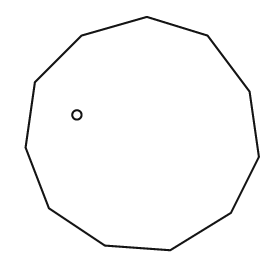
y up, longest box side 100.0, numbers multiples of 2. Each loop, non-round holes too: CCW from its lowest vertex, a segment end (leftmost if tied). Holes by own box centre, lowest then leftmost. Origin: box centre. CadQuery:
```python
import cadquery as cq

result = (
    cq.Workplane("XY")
    .moveTo(12.0, -50.0)
    .lineTo(38.0, -34.0)
    .lineTo(50.0, -10.0)
    .lineTo(46.0, 18.0)
    .lineTo(28.0, 42.0)
    .lineTo(2.0, 50.0)
    .lineTo(-26.0, 42.0)
    .lineTo(-46.0, 22.0)
    .lineTo(-50.0, -6.0)
    .lineTo(-40.0, -32.0)
    .lineTo(-16.0, -48.0)
    .close()
    .moveTo(-28.0, 8.0)
    .circle(2.0)
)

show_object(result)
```